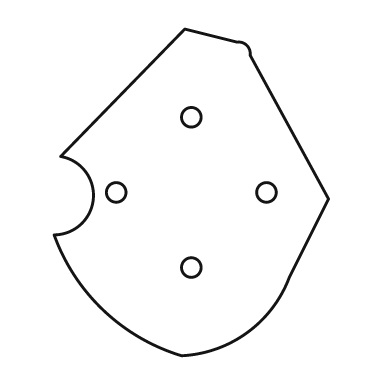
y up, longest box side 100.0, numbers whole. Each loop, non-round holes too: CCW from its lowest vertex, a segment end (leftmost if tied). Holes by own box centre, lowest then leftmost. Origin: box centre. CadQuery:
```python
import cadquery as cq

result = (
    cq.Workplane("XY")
    .moveTo(-3.0, -50.0)
    .threePointArc((17.0, -43.0), (30.0, -26.0))
    .lineTo(42.0, -2.0)
    .lineTo(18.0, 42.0)
    .threePointArc((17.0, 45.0), (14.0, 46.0))
    .lineTo(-2.0, 50.0)
    .lineTo(-40.0, 11.0)
    .threePointArc((-30.0, -2.0), (-42.0, -13.0))
    .threePointArc((-27.0, -36.0), (-3.0, -50.0))
    .close()
    .moveTo(0.0, -23.0)
    .circle(3.0)
    .moveTo(-23.0, 0.0)
    .circle(3.0)
    .moveTo(23.0, 0.0)
    .circle(3.0)
    .moveTo(0.0, 23.0)
    .circle(3.0)
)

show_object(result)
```